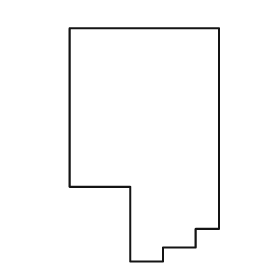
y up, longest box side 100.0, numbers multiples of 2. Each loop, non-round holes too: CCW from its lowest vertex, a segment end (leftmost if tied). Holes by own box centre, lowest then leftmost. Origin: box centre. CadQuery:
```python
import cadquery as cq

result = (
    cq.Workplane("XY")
    .moveTo(-6.0, -50.0)
    .lineTo(8.0, -50.0)
    .lineTo(8.0, -44.0)
    .lineTo(22.0, -44.0)
    .lineTo(22.0, -36.0)
    .lineTo(32.0, -36.0)
    .lineTo(32.0, 50.0)
    .lineTo(-32.0, 50.0)
    .lineTo(-32.0, -18.0)
    .lineTo(-6.0, -18.0)
    .close()
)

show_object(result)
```